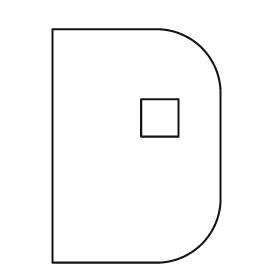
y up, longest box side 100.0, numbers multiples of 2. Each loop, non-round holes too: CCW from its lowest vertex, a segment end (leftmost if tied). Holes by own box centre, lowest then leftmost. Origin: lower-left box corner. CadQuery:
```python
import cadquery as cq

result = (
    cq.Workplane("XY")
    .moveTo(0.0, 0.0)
    .lineTo(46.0, 0.0)
    .threePointArc((64.0, 8.0), (72.0, 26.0))
    .lineTo(72.0, 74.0)
    .threePointArc((64.0, 92.0), (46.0, 100.0))
    .lineTo(0.0, 100.0)
    .close()
    .moveTo(38.0, 54.0)
    .lineTo(54.0, 54.0)
    .lineTo(54.0, 70.0)
    .lineTo(38.0, 70.0)
    .close()
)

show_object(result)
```